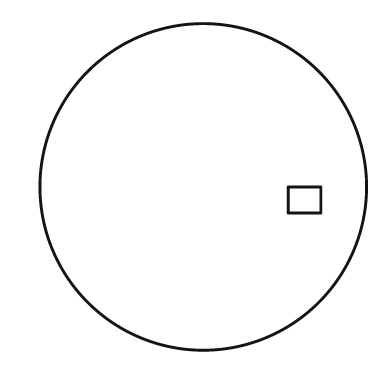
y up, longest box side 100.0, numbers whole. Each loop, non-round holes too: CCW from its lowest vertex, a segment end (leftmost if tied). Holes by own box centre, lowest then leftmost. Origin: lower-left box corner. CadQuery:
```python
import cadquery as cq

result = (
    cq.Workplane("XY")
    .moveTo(50.0, 50.0)
    .circle(50.0)
    .moveTo(76.0, 42.0)
    .lineTo(86.0, 42.0)
    .lineTo(86.0, 50.0)
    .lineTo(76.0, 50.0)
    .close()
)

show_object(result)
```